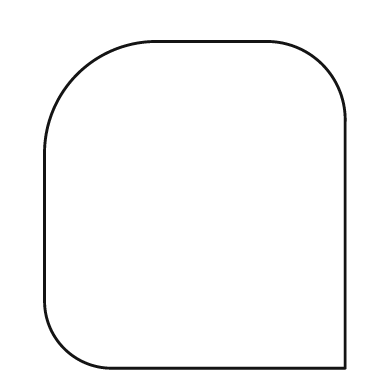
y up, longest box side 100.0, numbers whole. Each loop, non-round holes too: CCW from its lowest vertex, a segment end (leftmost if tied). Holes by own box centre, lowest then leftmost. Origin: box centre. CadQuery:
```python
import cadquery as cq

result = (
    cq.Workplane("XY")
    .moveTo(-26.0, -50.0)
    .lineTo(46.0, -50.0)
    .lineTo(46.0, 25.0)
    .threePointArc((39.0, 43.0), (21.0, 50.0))
    .lineTo(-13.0, 50.0)
    .threePointArc((-36.0, 40.0), (-46.0, 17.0))
    .lineTo(-46.0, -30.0)
    .threePointArc((-40.0, -44.0), (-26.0, -50.0))
    .close()
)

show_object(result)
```